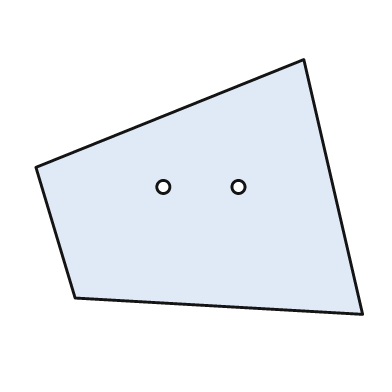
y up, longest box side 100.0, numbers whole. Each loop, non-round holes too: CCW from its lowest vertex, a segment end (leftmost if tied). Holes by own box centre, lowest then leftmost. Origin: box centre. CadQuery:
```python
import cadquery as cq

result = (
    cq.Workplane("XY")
    .moveTo(50.0, -39.0)
    .lineTo(32.0, 39.0)
    .lineTo(-50.0, 6.0)
    .lineTo(-38.0, -34.0)
    .close()
    .moveTo(-11.0, 0.0)
    .circle(2.0)
    .moveTo(12.0, 0.0)
    .circle(2.0)
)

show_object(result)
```